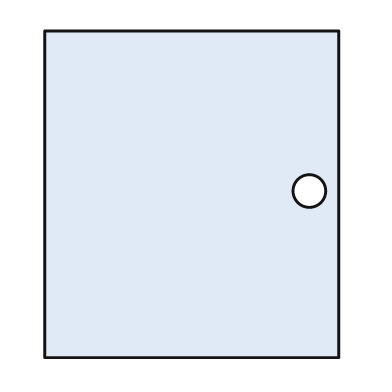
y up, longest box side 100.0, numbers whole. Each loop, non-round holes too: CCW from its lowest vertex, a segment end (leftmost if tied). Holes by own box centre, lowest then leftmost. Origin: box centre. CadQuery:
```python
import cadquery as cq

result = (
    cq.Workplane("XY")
    .moveTo(-45.0, -50.0)
    .lineTo(45.0, -50.0)
    .lineTo(45.0, 50.0)
    .lineTo(-45.0, 50.0)
    .close()
    .moveTo(36.0, 1.0)
    .circle(5.0)
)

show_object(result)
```